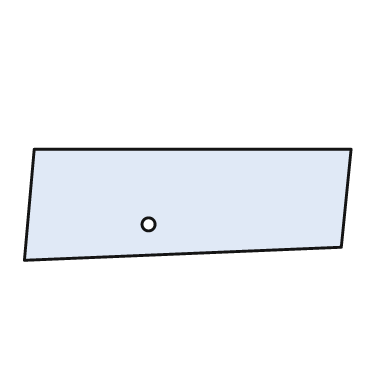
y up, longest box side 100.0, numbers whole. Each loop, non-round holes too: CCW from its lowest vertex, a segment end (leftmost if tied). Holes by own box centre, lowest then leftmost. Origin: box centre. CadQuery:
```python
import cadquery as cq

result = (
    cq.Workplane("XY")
    .moveTo(-50.0, -17.0)
    .lineTo(47.0, -13.0)
    .lineTo(50.0, 17.0)
    .lineTo(-47.0, 17.0)
    .close()
    .moveTo(-12.0, -6.0)
    .circle(2.0)
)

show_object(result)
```